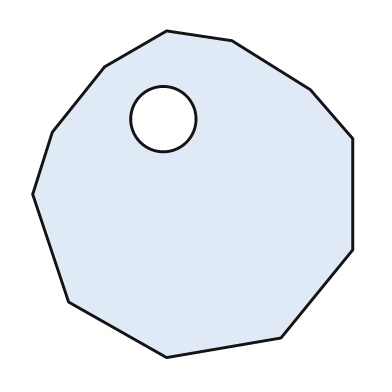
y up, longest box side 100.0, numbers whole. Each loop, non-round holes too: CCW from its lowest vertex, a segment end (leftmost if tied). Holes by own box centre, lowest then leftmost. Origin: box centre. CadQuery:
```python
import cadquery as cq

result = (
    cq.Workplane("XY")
    .moveTo(-8.0, -50.0)
    .lineTo(27.0, -44.0)
    .lineTo(49.0, -17.0)
    .lineTo(49.0, 17.0)
    .lineTo(36.0, 32.0)
    .lineTo(12.0, 47.0)
    .lineTo(-8.0, 50.0)
    .lineTo(-27.0, 39.0)
    .lineTo(-43.0, 19.0)
    .lineTo(-49.0, 0.0)
    .lineTo(-38.0, -33.0)
    .close()
    .moveTo(-9.0, 23.0)
    .circle(10.0)
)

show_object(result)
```